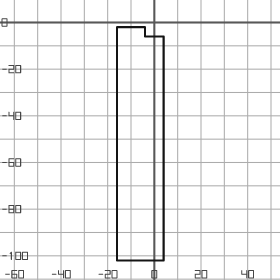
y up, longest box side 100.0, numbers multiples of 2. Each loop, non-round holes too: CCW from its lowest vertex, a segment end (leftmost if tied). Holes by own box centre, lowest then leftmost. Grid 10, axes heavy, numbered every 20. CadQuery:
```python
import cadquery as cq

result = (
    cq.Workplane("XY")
    .moveTo(-16.0, -102.0)
    .lineTo(4.0, -102.0)
    .lineTo(4.0, -6.0)
    .lineTo(-4.0, -6.0)
    .lineTo(-4.0, -2.0)
    .lineTo(-16.0, -2.0)
    .close()
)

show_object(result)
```